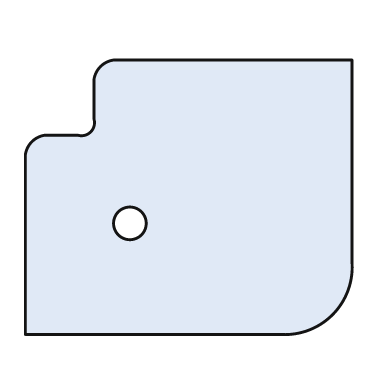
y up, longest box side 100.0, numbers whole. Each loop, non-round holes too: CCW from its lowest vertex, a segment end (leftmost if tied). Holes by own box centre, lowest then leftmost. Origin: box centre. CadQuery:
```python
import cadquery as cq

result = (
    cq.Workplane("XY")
    .moveTo(-50.0, -42.0)
    .lineTo(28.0, -42.0)
    .threePointArc((44.0, -36.0), (50.0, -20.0))
    .lineTo(50.0, 42.0)
    .lineTo(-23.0, 42.0)
    .threePointArc((-27.0, 40.0), (-29.0, 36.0))
    .lineTo(-29.0, 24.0)
    .threePointArc((-30.0, 20.0), (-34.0, 19.0))
    .lineTo(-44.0, 19.0)
    .threePointArc((-48.0, 17.0), (-50.0, 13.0))
    .close()
    .moveTo(-18.0, -8.0)
    .circle(5.0)
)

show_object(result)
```